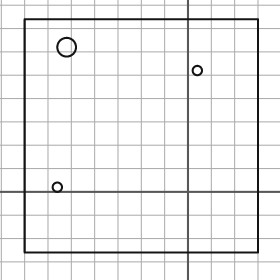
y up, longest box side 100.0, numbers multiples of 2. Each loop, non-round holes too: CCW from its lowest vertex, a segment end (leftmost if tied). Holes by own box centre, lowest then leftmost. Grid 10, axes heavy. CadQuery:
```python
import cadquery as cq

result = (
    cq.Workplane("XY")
    .moveTo(-70.0, -26.0)
    .lineTo(30.0, -26.0)
    .lineTo(30.0, 74.0)
    .lineTo(-70.0, 74.0)
    .close()
    .moveTo(-56.0, 2.0)
    .circle(2.0)
    .moveTo(4.0, 52.0)
    .circle(2.0)
    .moveTo(-52.0, 62.0)
    .circle(4.0)
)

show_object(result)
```